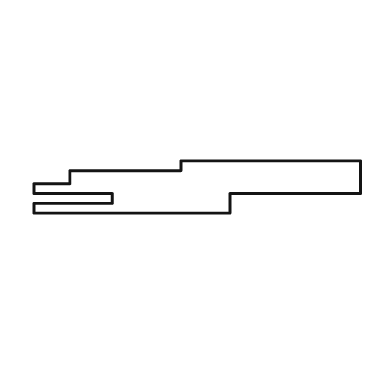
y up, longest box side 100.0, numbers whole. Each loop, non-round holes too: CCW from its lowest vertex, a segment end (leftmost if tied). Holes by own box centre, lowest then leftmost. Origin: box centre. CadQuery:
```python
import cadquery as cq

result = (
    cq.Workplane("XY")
    .moveTo(-50.0, -8.0)
    .lineTo(10.0, -8.0)
    .lineTo(10.0, -2.0)
    .lineTo(50.0, -2.0)
    .lineTo(50.0, 8.0)
    .lineTo(-5.0, 8.0)
    .lineTo(-5.0, 5.0)
    .lineTo(-39.0, 5.0)
    .lineTo(-39.0, 1.0)
    .lineTo(-50.0, 1.0)
    .lineTo(-50.0, -2.0)
    .lineTo(-26.0, -2.0)
    .lineTo(-26.0, -5.0)
    .lineTo(-50.0, -5.0)
    .close()
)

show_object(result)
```